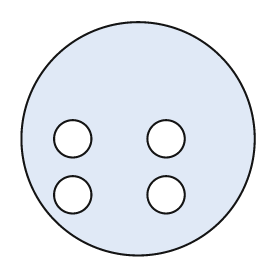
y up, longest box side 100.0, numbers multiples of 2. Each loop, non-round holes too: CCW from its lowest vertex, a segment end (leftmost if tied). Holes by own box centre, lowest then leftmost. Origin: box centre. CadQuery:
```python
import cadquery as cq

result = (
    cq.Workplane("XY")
    .moveTo(0.0, 0.0)
    .circle(50.0)
    .moveTo(-28.0, -24.0)
    .circle(8.0)
    .moveTo(12.0, -24.0)
    .circle(8.0)
    .moveTo(-28.0, 0.0)
    .circle(8.0)
    .moveTo(12.0, 0.0)
    .circle(8.0)
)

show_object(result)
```